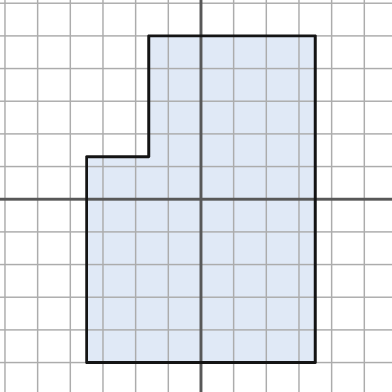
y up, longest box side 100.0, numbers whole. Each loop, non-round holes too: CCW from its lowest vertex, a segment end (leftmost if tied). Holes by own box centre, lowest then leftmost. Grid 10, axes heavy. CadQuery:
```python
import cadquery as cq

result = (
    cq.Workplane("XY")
    .moveTo(-35.0, -50.0)
    .lineTo(35.0, -50.0)
    .lineTo(35.0, 50.0)
    .lineTo(-16.0, 50.0)
    .lineTo(-16.0, 13.0)
    .lineTo(-35.0, 13.0)
    .close()
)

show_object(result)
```